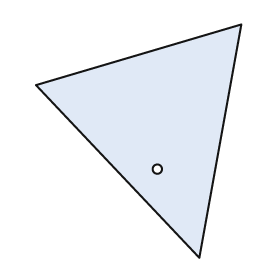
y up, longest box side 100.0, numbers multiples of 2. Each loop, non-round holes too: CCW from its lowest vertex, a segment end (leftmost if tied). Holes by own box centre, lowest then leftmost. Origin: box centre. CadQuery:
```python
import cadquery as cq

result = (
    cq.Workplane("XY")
    .moveTo(26.0, -50.0)
    .lineTo(44.0, 50.0)
    .lineTo(-44.0, 24.0)
    .close()
    .moveTo(8.0, -12.0)
    .circle(2.0)
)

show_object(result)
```